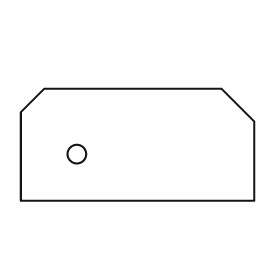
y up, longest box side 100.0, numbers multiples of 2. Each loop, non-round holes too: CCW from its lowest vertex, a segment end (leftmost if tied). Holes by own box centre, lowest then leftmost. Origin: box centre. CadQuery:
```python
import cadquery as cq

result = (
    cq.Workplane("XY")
    .moveTo(-50.0, -24.0)
    .lineTo(50.0, -24.0)
    .lineTo(50.0, 10.0)
    .lineTo(36.0, 24.0)
    .lineTo(-40.0, 24.0)
    .lineTo(-50.0, 14.0)
    .close()
    .moveTo(-26.0, -4.0)
    .circle(4.0)
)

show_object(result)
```